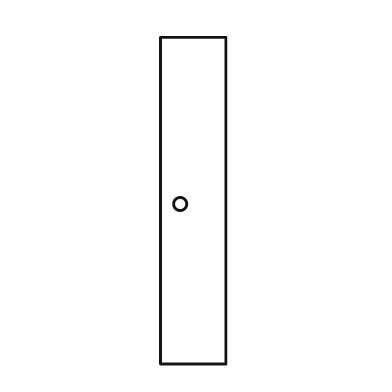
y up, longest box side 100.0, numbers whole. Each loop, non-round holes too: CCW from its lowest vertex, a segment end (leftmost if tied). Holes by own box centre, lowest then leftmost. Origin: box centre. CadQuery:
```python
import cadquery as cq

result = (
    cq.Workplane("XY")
    .moveTo(-10.0, -50.0)
    .lineTo(10.0, -50.0)
    .lineTo(10.0, 50.0)
    .lineTo(-10.0, 50.0)
    .close()
    .moveTo(-4.0, -1.0)
    .circle(2.0)
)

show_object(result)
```